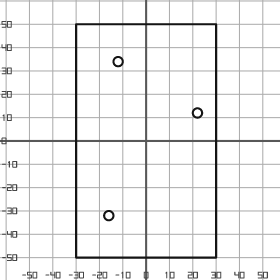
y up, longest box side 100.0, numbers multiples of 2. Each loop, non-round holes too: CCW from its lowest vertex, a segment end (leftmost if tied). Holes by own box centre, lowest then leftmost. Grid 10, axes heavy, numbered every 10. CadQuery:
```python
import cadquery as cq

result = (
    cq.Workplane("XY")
    .moveTo(-30.0, -50.0)
    .lineTo(30.0, -50.0)
    .lineTo(30.0, 50.0)
    .lineTo(-30.0, 50.0)
    .close()
    .moveTo(-16.0, -32.0)
    .circle(2.0)
    .moveTo(22.0, 12.0)
    .circle(2.0)
    .moveTo(-12.0, 34.0)
    .circle(2.0)
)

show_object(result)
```